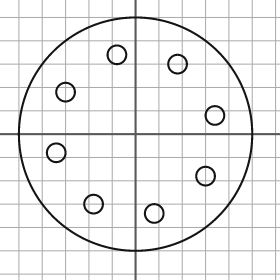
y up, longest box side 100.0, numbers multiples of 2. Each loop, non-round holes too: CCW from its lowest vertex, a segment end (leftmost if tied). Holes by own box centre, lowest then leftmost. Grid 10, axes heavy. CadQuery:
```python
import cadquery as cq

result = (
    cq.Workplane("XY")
    .moveTo(0.0, 0.0)
    .circle(50.0)
    .moveTo(8.0, -34.0)
    .circle(4.0)
    .moveTo(-18.0, -30.0)
    .circle(4.0)
    .moveTo(30.0, -18.0)
    .circle(4.0)
    .moveTo(-34.0, -8.0)
    .circle(4.0)
    .moveTo(34.0, 8.0)
    .circle(4.0)
    .moveTo(-30.0, 18.0)
    .circle(4.0)
    .moveTo(18.0, 30.0)
    .circle(4.0)
    .moveTo(-8.0, 34.0)
    .circle(4.0)
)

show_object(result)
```